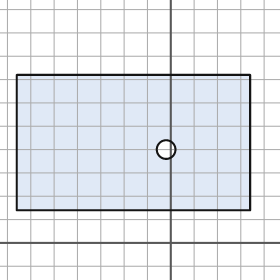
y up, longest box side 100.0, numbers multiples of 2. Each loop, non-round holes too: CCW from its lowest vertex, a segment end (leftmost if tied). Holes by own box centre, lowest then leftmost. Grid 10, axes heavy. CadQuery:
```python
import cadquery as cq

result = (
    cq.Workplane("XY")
    .moveTo(-66.0, 14.0)
    .lineTo(34.0, 14.0)
    .lineTo(34.0, 72.0)
    .lineTo(-66.0, 72.0)
    .close()
    .moveTo(-2.0, 40.0)
    .circle(4.0)
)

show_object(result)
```